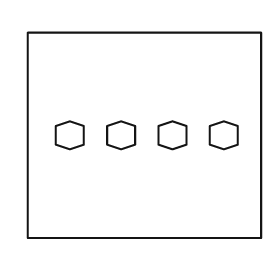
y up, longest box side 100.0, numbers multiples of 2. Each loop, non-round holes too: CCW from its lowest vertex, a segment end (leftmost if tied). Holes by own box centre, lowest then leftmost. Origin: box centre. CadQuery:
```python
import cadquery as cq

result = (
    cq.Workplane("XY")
    .moveTo(-50.0, -44.0)
    .lineTo(50.0, -44.0)
    .lineTo(50.0, 44.0)
    .lineTo(-50.0, 44.0)
    .close()
    .moveTo(-32.0, -6.0)
    .lineTo(-26.0, -4.0)
    .lineTo(-26.0, 4.0)
    .lineTo(-32.0, 6.0)
    .lineTo(-38.0, 4.0)
    .lineTo(-38.0, -4.0)
    .close()
    .moveTo(-10.0, -6.0)
    .lineTo(-4.0, -4.0)
    .lineTo(-4.0, 4.0)
    .lineTo(-10.0, 6.0)
    .lineTo(-16.0, 4.0)
    .lineTo(-16.0, -4.0)
    .close()
    .moveTo(12.0, -6.0)
    .lineTo(18.0, -4.0)
    .lineTo(18.0, 4.0)
    .lineTo(12.0, 6.0)
    .lineTo(6.0, 4.0)
    .lineTo(6.0, -4.0)
    .close()
    .moveTo(34.0, -6.0)
    .lineTo(40.0, -4.0)
    .lineTo(40.0, 4.0)
    .lineTo(34.0, 6.0)
    .lineTo(28.0, 4.0)
    .lineTo(28.0, -4.0)
    .close()
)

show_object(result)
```